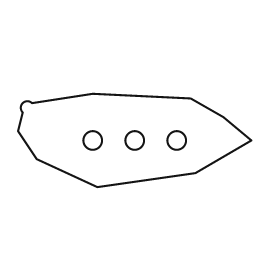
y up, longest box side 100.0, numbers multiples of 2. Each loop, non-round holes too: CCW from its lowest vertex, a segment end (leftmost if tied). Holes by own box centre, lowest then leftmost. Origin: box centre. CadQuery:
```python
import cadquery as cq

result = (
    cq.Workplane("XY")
    .moveTo(-16.0, -20.0)
    .lineTo(26.0, -14.0)
    .lineTo(50.0, 0.0)
    .lineTo(38.0, 10.0)
    .lineTo(24.0, 18.0)
    .lineTo(-18.0, 20.0)
    .lineTo(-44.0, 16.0)
    .threePointArc((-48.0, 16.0), (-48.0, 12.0))
    .lineTo(-50.0, 4.0)
    .lineTo(-42.0, -8.0)
    .close()
    .moveTo(-18.0, 0.0)
    .circle(4.0)
    .moveTo(0.0, 0.0)
    .circle(4.0)
    .moveTo(18.0, 0.0)
    .circle(4.0)
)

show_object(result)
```